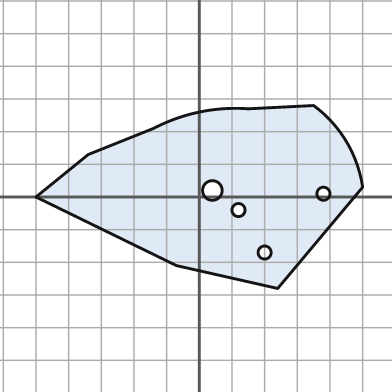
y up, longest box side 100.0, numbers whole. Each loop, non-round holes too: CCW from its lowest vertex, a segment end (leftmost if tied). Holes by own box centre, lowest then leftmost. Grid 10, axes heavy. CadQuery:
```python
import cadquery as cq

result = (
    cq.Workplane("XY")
    .moveTo(24.0, -28.0)
    .lineTo(50.0, 3.0)
    .threePointArc((45.0, 17.0), (35.0, 28.0))
    .lineTo(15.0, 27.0)
    .threePointArc((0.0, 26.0), (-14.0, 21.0))
    .lineTo(-34.0, 13.0)
    .lineTo(-50.0, 0.0)
    .lineTo(-7.0, -21.0)
    .close()
    .moveTo(20.0, -17.0)
    .circle(2.0)
    .moveTo(12.0, -4.0)
    .circle(2.0)
    .moveTo(38.0, 1.0)
    .circle(2.0)
    .moveTo(4.0, 2.0)
    .circle(3.0)
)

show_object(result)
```